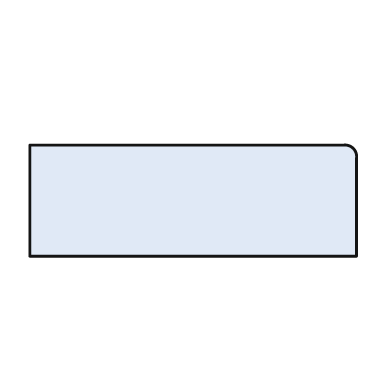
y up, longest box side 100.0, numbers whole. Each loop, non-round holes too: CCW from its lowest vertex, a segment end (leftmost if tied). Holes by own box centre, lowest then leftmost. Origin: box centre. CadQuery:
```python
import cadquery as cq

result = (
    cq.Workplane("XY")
    .moveTo(-50.0, -17.0)
    .lineTo(50.0, -17.0)
    .lineTo(50.0, 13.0)
    .threePointArc((49.0, 16.0), (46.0, 17.0))
    .lineTo(-50.0, 17.0)
    .close()
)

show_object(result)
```